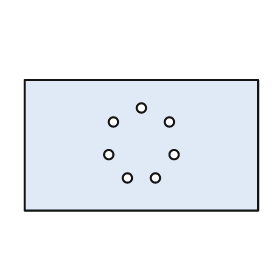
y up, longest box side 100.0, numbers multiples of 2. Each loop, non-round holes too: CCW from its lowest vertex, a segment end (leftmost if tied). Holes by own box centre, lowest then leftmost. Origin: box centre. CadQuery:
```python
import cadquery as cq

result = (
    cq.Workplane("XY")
    .moveTo(-50.0, -28.0)
    .lineTo(50.0, -28.0)
    .lineTo(50.0, 28.0)
    .lineTo(-50.0, 28.0)
    .close()
    .moveTo(-6.0, -14.0)
    .circle(2.0)
    .moveTo(6.0, -14.0)
    .circle(2.0)
    .moveTo(-14.0, -4.0)
    .circle(2.0)
    .moveTo(14.0, -4.0)
    .circle(2.0)
    .moveTo(-12.0, 10.0)
    .circle(2.0)
    .moveTo(12.0, 10.0)
    .circle(2.0)
    .moveTo(0.0, 16.0)
    .circle(2.0)
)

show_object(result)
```